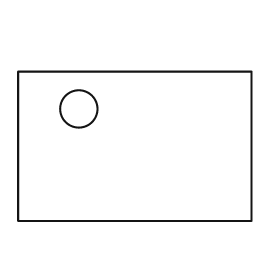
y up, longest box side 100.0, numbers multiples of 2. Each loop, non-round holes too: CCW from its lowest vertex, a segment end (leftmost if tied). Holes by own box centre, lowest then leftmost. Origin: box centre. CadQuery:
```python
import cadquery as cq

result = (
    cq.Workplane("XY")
    .moveTo(-50.0, -32.0)
    .lineTo(50.0, -32.0)
    .lineTo(50.0, 32.0)
    .lineTo(-50.0, 32.0)
    .close()
    .moveTo(-24.0, 16.0)
    .circle(8.0)
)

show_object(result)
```